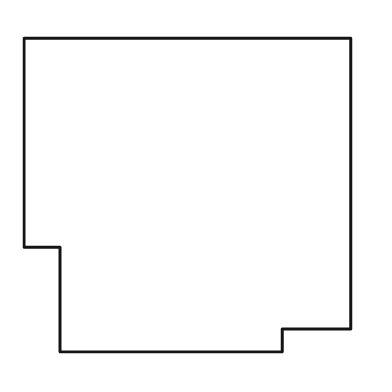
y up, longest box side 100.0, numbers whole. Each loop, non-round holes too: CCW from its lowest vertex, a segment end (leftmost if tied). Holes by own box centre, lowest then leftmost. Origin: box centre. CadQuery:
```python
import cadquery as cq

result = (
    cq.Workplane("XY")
    .moveTo(-39.0, -48.0)
    .lineTo(29.0, -48.0)
    .lineTo(29.0, -41.0)
    .lineTo(50.0, -41.0)
    .lineTo(50.0, 48.0)
    .lineTo(-50.0, 48.0)
    .lineTo(-50.0, -16.0)
    .lineTo(-39.0, -16.0)
    .close()
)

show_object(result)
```